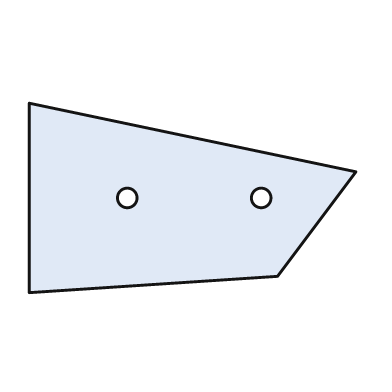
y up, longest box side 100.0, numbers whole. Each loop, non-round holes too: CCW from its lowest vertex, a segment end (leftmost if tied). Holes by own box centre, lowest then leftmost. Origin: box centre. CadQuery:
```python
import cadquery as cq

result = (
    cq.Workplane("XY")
    .moveTo(-50.0, -29.0)
    .lineTo(26.0, -24.0)
    .lineTo(50.0, 8.0)
    .lineTo(-50.0, 29.0)
    .close()
    .moveTo(-20.0, 0.0)
    .circle(3.0)
    .moveTo(21.0, 0.0)
    .circle(3.0)
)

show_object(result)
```